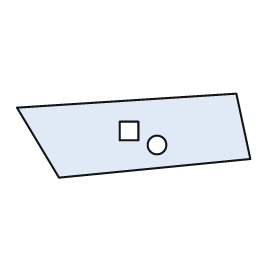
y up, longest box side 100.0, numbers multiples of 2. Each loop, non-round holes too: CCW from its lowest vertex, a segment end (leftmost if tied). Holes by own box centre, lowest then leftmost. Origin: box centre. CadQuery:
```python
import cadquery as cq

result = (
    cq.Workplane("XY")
    .moveTo(-32.0, -18.0)
    .lineTo(50.0, -10.0)
    .lineTo(44.0, 18.0)
    .lineTo(-50.0, 12.0)
    .close()
    .moveTo(10.0, -4.0)
    .circle(4.0)
    .moveTo(-6.0, -2.0)
    .lineTo(2.0, -2.0)
    .lineTo(2.0, 6.0)
    .lineTo(-6.0, 6.0)
    .close()
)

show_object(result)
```